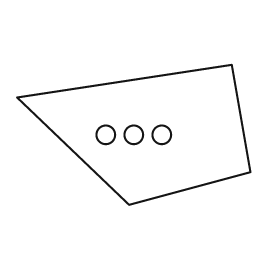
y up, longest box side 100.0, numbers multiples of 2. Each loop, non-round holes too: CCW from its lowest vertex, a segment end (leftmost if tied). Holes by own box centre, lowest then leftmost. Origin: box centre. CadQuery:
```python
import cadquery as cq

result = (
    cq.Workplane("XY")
    .moveTo(-2.0, -30.0)
    .lineTo(50.0, -16.0)
    .lineTo(42.0, 30.0)
    .lineTo(-50.0, 16.0)
    .close()
    .moveTo(-12.0, 0.0)
    .circle(4.0)
    .moveTo(0.0, 0.0)
    .circle(4.0)
    .moveTo(12.0, 0.0)
    .circle(4.0)
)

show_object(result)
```